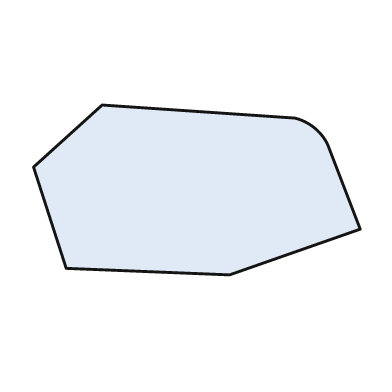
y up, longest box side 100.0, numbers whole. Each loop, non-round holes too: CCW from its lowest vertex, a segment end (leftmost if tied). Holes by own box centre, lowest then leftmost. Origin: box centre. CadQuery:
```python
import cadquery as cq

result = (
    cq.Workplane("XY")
    .moveTo(10.0, -26.0)
    .lineTo(50.0, -12.0)
    .lineTo(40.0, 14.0)
    .threePointArc((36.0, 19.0), (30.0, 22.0))
    .lineTo(-29.0, 26.0)
    .lineTo(-50.0, 7.0)
    .lineTo(-40.0, -24.0)
    .close()
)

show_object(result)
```